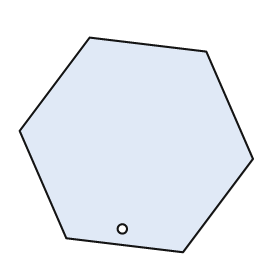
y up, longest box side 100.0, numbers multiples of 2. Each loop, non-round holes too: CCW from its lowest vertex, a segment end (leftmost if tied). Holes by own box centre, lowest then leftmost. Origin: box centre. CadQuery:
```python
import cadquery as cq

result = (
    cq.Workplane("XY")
    .moveTo(20.0, -46.0)
    .lineTo(50.0, -6.0)
    .lineTo(30.0, 40.0)
    .lineTo(-20.0, 46.0)
    .lineTo(-50.0, 6.0)
    .lineTo(-30.0, -40.0)
    .close()
    .moveTo(-6.0, -36.0)
    .circle(2.0)
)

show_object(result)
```